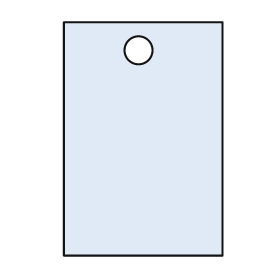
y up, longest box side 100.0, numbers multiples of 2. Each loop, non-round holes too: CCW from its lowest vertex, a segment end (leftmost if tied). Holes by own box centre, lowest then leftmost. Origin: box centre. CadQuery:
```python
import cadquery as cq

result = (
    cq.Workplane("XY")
    .moveTo(-34.0, -50.0)
    .lineTo(34.0, -50.0)
    .lineTo(34.0, 50.0)
    .lineTo(-34.0, 50.0)
    .close()
    .moveTo(-2.0, 38.0)
    .circle(6.0)
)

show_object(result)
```